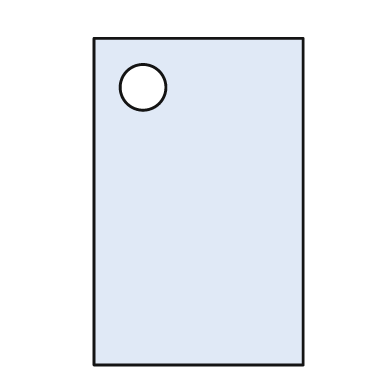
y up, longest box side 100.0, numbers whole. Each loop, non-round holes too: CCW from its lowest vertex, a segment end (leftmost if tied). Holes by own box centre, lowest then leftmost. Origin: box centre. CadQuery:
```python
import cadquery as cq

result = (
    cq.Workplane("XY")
    .moveTo(-32.0, -50.0)
    .lineTo(32.0, -50.0)
    .lineTo(32.0, 50.0)
    .lineTo(-32.0, 50.0)
    .close()
    .moveTo(-17.0, 35.0)
    .circle(7.0)
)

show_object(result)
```